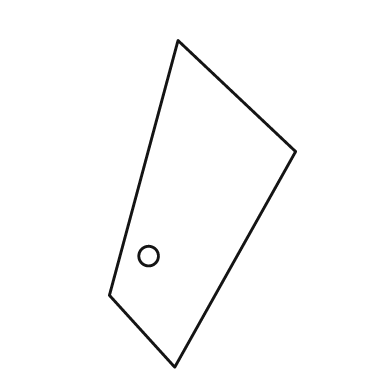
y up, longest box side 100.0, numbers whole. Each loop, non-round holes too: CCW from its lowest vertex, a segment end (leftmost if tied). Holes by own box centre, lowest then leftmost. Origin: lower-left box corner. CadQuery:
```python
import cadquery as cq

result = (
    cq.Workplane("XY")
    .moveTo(20.0, 0.0)
    .lineTo(57.0, 66.0)
    .lineTo(21.0, 100.0)
    .lineTo(0.0, 22.0)
    .close()
    .moveTo(12.0, 34.0)
    .circle(3.0)
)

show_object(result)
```